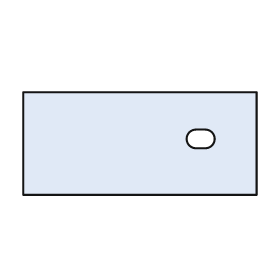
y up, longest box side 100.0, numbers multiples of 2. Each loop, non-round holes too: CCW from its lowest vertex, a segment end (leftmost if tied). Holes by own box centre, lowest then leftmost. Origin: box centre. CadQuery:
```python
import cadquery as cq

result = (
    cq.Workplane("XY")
    .moveTo(-50.0, -22.0)
    .lineTo(50.0, -22.0)
    .lineTo(50.0, 22.0)
    .lineTo(-50.0, 22.0)
    .close()
    .moveTo(24.0, -2.0)
    .lineTo(28.0, -2.0)
    .threePointArc((32.0, 2.0), (28.0, 6.0))
    .lineTo(24.0, 6.0)
    .threePointArc((20.0, 2.0), (24.0, -2.0))
    .close()
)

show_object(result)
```